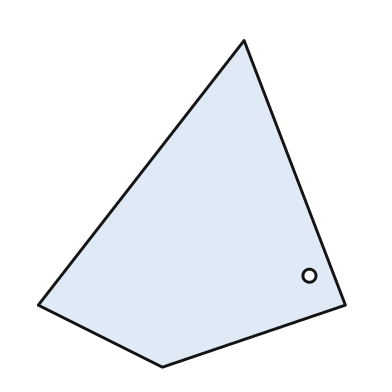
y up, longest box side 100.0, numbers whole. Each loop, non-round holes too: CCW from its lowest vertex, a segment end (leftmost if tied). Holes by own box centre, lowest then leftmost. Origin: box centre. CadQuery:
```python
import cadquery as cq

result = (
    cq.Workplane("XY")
    .moveTo(-9.0, -50.0)
    .lineTo(47.0, -31.0)
    .lineTo(16.0, 50.0)
    .lineTo(-47.0, -31.0)
    .close()
    .moveTo(36.0, -22.0)
    .circle(2.0)
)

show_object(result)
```